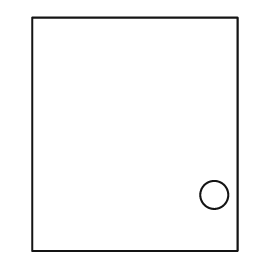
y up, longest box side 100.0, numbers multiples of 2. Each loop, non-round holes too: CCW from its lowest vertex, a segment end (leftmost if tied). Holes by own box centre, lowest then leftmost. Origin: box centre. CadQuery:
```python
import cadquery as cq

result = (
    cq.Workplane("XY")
    .moveTo(-44.0, -50.0)
    .lineTo(44.0, -50.0)
    .lineTo(44.0, 50.0)
    .lineTo(-44.0, 50.0)
    .close()
    .moveTo(34.0, -26.0)
    .circle(6.0)
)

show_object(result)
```